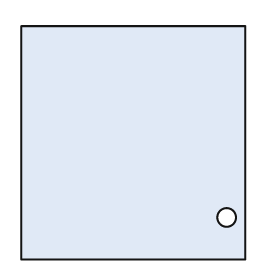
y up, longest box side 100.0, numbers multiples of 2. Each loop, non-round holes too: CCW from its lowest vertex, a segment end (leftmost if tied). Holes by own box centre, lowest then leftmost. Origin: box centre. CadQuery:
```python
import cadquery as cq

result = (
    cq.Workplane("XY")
    .moveTo(-48.0, -50.0)
    .lineTo(48.0, -50.0)
    .lineTo(48.0, 50.0)
    .lineTo(-48.0, 50.0)
    .close()
    .moveTo(40.0, -32.0)
    .circle(4.0)
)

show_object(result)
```